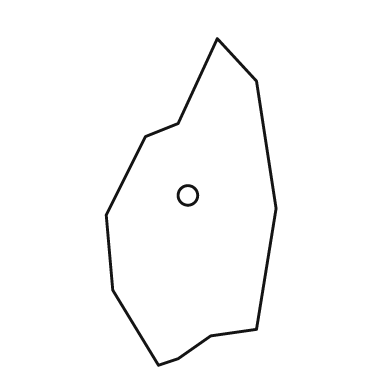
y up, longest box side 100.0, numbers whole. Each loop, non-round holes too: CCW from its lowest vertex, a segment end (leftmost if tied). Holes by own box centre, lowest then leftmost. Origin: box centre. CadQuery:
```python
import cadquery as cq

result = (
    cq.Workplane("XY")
    .moveTo(-10.0, -50.0)
    .lineTo(-4.0, -48.0)
    .lineTo(6.0, -41.0)
    .lineTo(20.0, -39.0)
    .lineTo(26.0, -2.0)
    .lineTo(20.0, 37.0)
    .lineTo(8.0, 50.0)
    .lineTo(-4.0, 24.0)
    .lineTo(-14.0, 20.0)
    .lineTo(-26.0, -4.0)
    .lineTo(-24.0, -27.0)
    .close()
    .moveTo(-1.0, 2.0)
    .circle(3.0)
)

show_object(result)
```